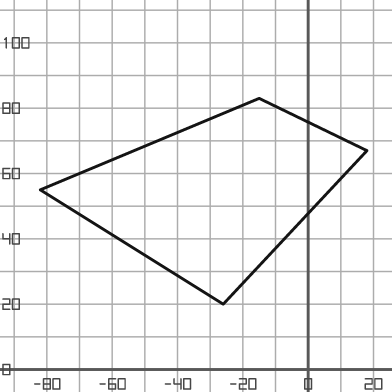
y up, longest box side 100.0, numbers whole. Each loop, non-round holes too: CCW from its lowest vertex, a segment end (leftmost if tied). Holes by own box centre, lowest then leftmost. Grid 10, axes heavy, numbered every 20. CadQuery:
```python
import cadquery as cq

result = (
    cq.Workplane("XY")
    .moveTo(-26.0, 20.0)
    .lineTo(18.0, 67.0)
    .lineTo(-15.0, 83.0)
    .lineTo(-82.0, 55.0)
    .close()
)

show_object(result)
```